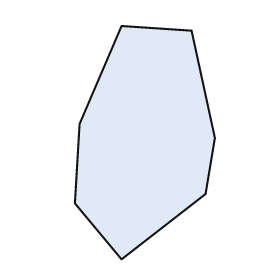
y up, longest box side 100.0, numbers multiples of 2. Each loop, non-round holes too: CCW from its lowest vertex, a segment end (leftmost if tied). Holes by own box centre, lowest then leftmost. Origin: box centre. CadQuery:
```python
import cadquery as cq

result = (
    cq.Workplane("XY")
    .moveTo(-10.0, -50.0)
    .lineTo(26.0, -22.0)
    .lineTo(30.0, 2.0)
    .lineTo(20.0, 48.0)
    .lineTo(-10.0, 50.0)
    .lineTo(-28.0, 8.0)
    .lineTo(-30.0, -26.0)
    .close()
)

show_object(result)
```